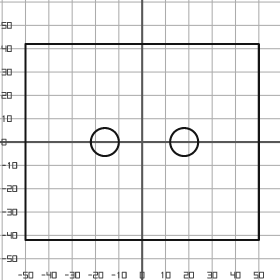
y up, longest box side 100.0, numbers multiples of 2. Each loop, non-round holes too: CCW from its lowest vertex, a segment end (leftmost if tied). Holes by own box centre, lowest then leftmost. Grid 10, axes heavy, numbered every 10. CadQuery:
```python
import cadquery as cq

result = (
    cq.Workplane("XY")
    .moveTo(-50.0, -42.0)
    .lineTo(50.0, -42.0)
    .lineTo(50.0, 42.0)
    .lineTo(-50.0, 42.0)
    .close()
    .moveTo(-16.0, 0.0)
    .circle(6.0)
    .moveTo(18.0, 0.0)
    .circle(6.0)
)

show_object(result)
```